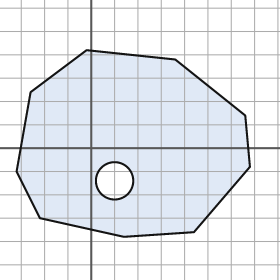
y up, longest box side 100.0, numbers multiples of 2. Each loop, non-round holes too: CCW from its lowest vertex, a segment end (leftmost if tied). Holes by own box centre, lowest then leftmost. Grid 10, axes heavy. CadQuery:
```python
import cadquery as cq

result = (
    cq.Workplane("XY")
    .moveTo(14.0, -38.0)
    .lineTo(44.0, -36.0)
    .lineTo(68.0, -8.0)
    .lineTo(66.0, 14.0)
    .lineTo(36.0, 38.0)
    .lineTo(-2.0, 42.0)
    .lineTo(-26.0, 24.0)
    .lineTo(-32.0, -10.0)
    .lineTo(-22.0, -30.0)
    .close()
    .moveTo(10.0, -14.0)
    .circle(8.0)
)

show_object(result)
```